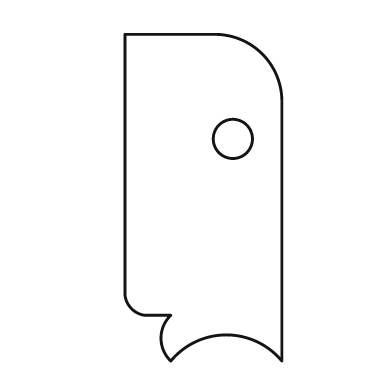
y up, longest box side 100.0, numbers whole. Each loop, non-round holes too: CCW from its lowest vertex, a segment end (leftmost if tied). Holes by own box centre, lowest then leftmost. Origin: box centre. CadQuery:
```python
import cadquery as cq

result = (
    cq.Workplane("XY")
    .moveTo(-10.0, -50.0)
    .threePointArc((7.0, -42.0), (24.0, -50.0))
    .lineTo(24.0, 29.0)
    .threePointArc((18.0, 44.0), (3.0, 50.0))
    .lineTo(-24.0, 50.0)
    .lineTo(-24.0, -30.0)
    .threePointArc((-22.0, -34.0), (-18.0, -36.0))
    .lineTo(-10.0, -36.0)
    .threePointArc((-13.0, -43.0), (-10.0, -50.0))
    .close()
    .moveTo(9.0, 18.0)
    .circle(6.0)
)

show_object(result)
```